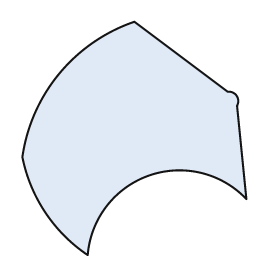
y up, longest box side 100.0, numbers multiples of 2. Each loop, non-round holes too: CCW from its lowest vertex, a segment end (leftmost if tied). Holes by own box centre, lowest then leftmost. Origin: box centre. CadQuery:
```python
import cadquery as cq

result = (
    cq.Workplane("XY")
    .moveTo(-20.0, -50.0)
    .threePointArc((6.0, -16.0), (48.0, -26.0))
    .lineTo(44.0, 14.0)
    .threePointArc((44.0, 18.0), (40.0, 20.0))
    .lineTo(0.0, 50.0)
    .threePointArc((-32.0, 28.0), (-48.0, -8.0))
    .threePointArc((-38.0, -32.0), (-20.0, -50.0))
    .close()
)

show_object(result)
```